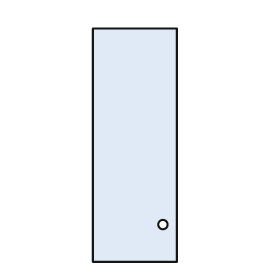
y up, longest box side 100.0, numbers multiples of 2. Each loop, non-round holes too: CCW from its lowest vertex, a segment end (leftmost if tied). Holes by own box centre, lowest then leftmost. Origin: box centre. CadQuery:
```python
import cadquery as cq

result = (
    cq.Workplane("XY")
    .moveTo(-18.0, -50.0)
    .lineTo(18.0, -50.0)
    .lineTo(18.0, 50.0)
    .lineTo(-18.0, 50.0)
    .close()
    .moveTo(12.0, -34.0)
    .circle(2.0)
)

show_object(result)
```